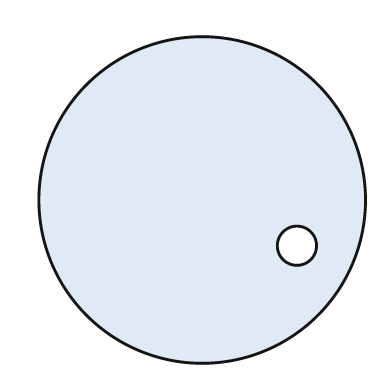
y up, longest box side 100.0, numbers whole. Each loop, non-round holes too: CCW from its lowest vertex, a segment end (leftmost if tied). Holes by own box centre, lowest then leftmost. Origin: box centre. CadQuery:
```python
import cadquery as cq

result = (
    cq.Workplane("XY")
    .moveTo(0.0, 0.0)
    .circle(50.0)
    .moveTo(29.0, -14.0)
    .circle(6.0)
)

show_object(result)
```